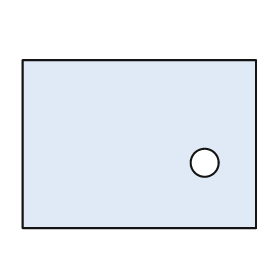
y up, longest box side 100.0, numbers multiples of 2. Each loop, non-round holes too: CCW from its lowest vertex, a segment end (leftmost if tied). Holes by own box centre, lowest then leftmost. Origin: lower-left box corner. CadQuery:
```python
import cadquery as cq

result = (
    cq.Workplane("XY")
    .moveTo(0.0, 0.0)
    .lineTo(100.0, 0.0)
    .lineTo(100.0, 72.0)
    .lineTo(0.0, 72.0)
    .close()
    .moveTo(78.0, 28.0)
    .circle(6.0)
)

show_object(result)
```